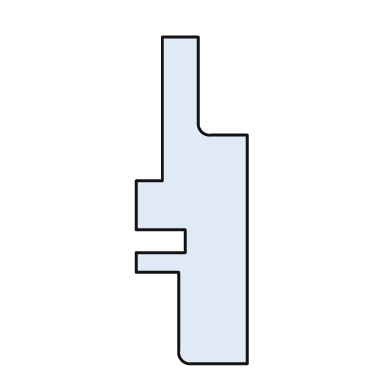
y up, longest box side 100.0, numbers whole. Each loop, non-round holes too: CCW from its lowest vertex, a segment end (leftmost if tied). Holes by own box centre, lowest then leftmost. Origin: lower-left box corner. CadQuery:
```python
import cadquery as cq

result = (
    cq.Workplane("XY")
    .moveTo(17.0, 0.0)
    .lineTo(34.0, 0.0)
    .lineTo(34.0, 70.0)
    .lineTo(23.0, 70.0)
    .threePointArc((20.0, 71.0), (19.0, 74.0))
    .lineTo(19.0, 100.0)
    .lineTo(8.0, 100.0)
    .lineTo(8.0, 56.0)
    .lineTo(0.0, 56.0)
    .lineTo(0.0, 41.0)
    .lineTo(15.0, 41.0)
    .lineTo(15.0, 34.0)
    .lineTo(0.0, 34.0)
    .lineTo(0.0, 28.0)
    .lineTo(13.0, 28.0)
    .lineTo(13.0, 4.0)
    .threePointArc((14.0, 1.0), (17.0, 0.0))
    .close()
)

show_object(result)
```